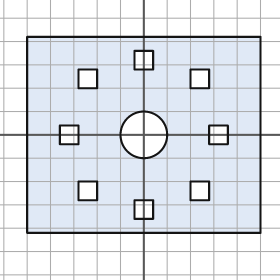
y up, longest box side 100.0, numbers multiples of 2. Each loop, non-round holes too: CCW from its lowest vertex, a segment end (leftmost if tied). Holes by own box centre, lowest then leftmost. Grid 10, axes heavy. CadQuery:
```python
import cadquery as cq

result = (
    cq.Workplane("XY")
    .moveTo(-50.0, -42.0)
    .lineTo(50.0, -42.0)
    .lineTo(50.0, 42.0)
    .lineTo(-50.0, 42.0)
    .close()
    .moveTo(-4.0, -36.0)
    .lineTo(4.0, -36.0)
    .lineTo(4.0, -28.0)
    .lineTo(-4.0, -28.0)
    .close()
    .moveTo(-28.0, -28.0)
    .lineTo(-20.0, -28.0)
    .lineTo(-20.0, -20.0)
    .lineTo(-28.0, -20.0)
    .close()
    .moveTo(20.0, -28.0)
    .lineTo(28.0, -28.0)
    .lineTo(28.0, -20.0)
    .lineTo(20.0, -20.0)
    .close()
    .moveTo(-36.0, -4.0)
    .lineTo(-28.0, -4.0)
    .lineTo(-28.0, 4.0)
    .lineTo(-36.0, 4.0)
    .close()
    .moveTo(0.0, 0.0)
    .circle(10.0)
    .moveTo(28.0, -4.0)
    .lineTo(36.0, -4.0)
    .lineTo(36.0, 4.0)
    .lineTo(28.0, 4.0)
    .close()
    .moveTo(-28.0, 20.0)
    .lineTo(-20.0, 20.0)
    .lineTo(-20.0, 28.0)
    .lineTo(-28.0, 28.0)
    .close()
    .moveTo(20.0, 20.0)
    .lineTo(28.0, 20.0)
    .lineTo(28.0, 28.0)
    .lineTo(20.0, 28.0)
    .close()
    .moveTo(-4.0, 28.0)
    .lineTo(4.0, 28.0)
    .lineTo(4.0, 36.0)
    .lineTo(-4.0, 36.0)
    .close()
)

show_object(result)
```